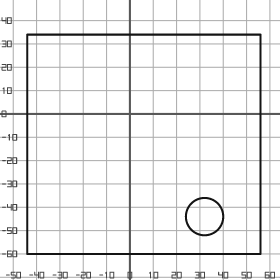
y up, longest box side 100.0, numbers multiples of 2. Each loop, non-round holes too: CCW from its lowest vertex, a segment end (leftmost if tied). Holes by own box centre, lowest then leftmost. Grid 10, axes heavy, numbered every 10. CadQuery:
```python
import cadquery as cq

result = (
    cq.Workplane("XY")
    .moveTo(-44.0, -60.0)
    .lineTo(56.0, -60.0)
    .lineTo(56.0, 34.0)
    .lineTo(-44.0, 34.0)
    .close()
    .moveTo(32.0, -44.0)
    .circle(8.0)
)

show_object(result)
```